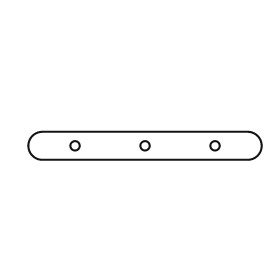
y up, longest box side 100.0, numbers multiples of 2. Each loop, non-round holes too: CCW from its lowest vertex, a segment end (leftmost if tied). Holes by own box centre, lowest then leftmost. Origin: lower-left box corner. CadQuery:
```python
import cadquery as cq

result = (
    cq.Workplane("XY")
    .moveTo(6.0, 0.0)
    .lineTo(94.0, 0.0)
    .threePointArc((100.0, 6.0), (94.0, 12.0))
    .lineTo(6.0, 12.0)
    .threePointArc((0.0, 6.0), (6.0, 0.0))
    .close()
    .moveTo(20.0, 6.0)
    .circle(2.0)
    .moveTo(50.0, 6.0)
    .circle(2.0)
    .moveTo(80.0, 6.0)
    .circle(2.0)
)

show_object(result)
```